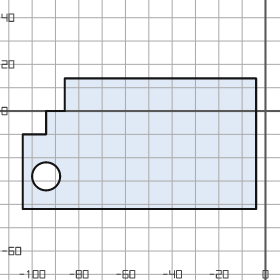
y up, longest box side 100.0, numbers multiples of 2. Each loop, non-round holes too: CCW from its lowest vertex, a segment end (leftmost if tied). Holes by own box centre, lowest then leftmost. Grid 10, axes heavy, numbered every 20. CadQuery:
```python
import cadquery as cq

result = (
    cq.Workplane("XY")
    .moveTo(-104.0, -42.0)
    .lineTo(-4.0, -42.0)
    .lineTo(-4.0, 14.0)
    .lineTo(-86.0, 14.0)
    .lineTo(-86.0, 0.0)
    .lineTo(-94.0, 0.0)
    .lineTo(-94.0, -10.0)
    .lineTo(-104.0, -10.0)
    .close()
    .moveTo(-94.0, -28.0)
    .circle(6.0)
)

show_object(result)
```